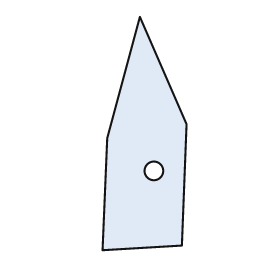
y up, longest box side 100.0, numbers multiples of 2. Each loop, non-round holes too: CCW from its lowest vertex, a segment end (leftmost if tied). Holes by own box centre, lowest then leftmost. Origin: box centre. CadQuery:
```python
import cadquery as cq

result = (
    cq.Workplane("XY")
    .moveTo(-18.0, -50.0)
    .lineTo(16.0, -48.0)
    .lineTo(18.0, 4.0)
    .lineTo(-2.0, 50.0)
    .lineTo(-16.0, -2.0)
    .close()
    .moveTo(4.0, -16.0)
    .circle(4.0)
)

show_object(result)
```